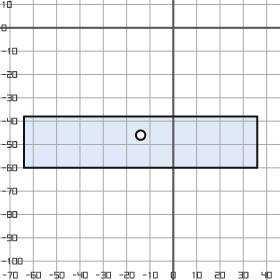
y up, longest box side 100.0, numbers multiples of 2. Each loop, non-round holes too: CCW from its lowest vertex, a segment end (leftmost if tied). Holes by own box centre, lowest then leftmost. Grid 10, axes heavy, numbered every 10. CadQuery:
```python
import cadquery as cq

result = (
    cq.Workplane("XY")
    .moveTo(-64.0, -60.0)
    .lineTo(36.0, -60.0)
    .lineTo(36.0, -38.0)
    .lineTo(-64.0, -38.0)
    .close()
    .moveTo(-14.0, -46.0)
    .circle(2.0)
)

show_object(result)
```